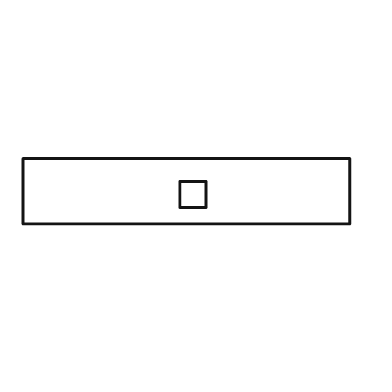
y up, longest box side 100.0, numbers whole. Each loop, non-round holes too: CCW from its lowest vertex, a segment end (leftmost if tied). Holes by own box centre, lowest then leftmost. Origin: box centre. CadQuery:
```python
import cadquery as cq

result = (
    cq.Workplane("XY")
    .moveTo(-50.0, -10.0)
    .lineTo(50.0, -10.0)
    .lineTo(50.0, 10.0)
    .lineTo(-50.0, 10.0)
    .close()
    .moveTo(-2.0, -5.0)
    .lineTo(6.0, -5.0)
    .lineTo(6.0, 3.0)
    .lineTo(-2.0, 3.0)
    .close()
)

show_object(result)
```